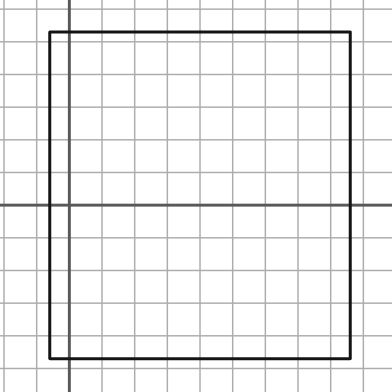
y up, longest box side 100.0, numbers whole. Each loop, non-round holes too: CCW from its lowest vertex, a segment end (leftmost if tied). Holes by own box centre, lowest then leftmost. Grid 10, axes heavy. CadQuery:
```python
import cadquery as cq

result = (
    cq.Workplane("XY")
    .moveTo(-6.0, -47.0)
    .lineTo(86.0, -47.0)
    .lineTo(86.0, 53.0)
    .lineTo(-6.0, 53.0)
    .close()
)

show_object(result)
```